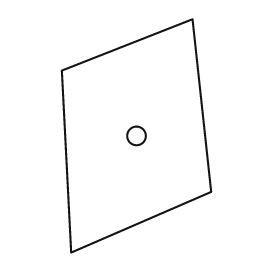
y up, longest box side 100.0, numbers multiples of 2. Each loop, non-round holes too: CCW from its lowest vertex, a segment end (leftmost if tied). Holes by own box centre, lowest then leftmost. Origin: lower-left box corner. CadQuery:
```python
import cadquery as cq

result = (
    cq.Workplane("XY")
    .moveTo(4.0, 0.0)
    .lineTo(64.0, 26.0)
    .lineTo(56.0, 100.0)
    .lineTo(0.0, 78.0)
    .close()
    .moveTo(32.0, 50.0)
    .circle(4.0)
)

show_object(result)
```